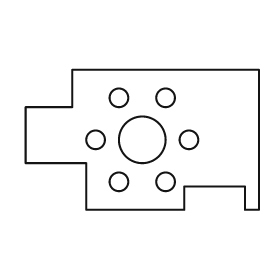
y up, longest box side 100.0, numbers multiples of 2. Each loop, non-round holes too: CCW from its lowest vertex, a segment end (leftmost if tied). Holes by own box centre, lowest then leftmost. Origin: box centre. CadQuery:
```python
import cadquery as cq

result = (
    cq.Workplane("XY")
    .moveTo(-24.0, -30.0)
    .lineTo(18.0, -30.0)
    .lineTo(18.0, -20.0)
    .lineTo(44.0, -20.0)
    .lineTo(44.0, -30.0)
    .lineTo(50.0, -30.0)
    .lineTo(50.0, 30.0)
    .lineTo(-30.0, 30.0)
    .lineTo(-30.0, 14.0)
    .lineTo(-50.0, 14.0)
    .lineTo(-50.0, -10.0)
    .lineTo(-24.0, -10.0)
    .close()
    .moveTo(-10.0, -18.0)
    .circle(4.0)
    .moveTo(10.0, -18.0)
    .circle(4.0)
    .moveTo(-20.0, 0.0)
    .circle(4.0)
    .moveTo(0.0, 0.0)
    .circle(10.0)
    .moveTo(20.0, 0.0)
    .circle(4.0)
    .moveTo(-10.0, 18.0)
    .circle(4.0)
    .moveTo(10.0, 18.0)
    .circle(4.0)
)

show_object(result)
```